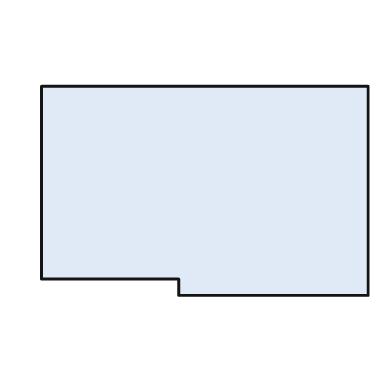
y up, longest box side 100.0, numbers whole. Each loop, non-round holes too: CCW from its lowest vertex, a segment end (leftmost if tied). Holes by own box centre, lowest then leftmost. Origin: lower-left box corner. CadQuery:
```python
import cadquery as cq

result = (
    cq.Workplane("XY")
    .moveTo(42.0, 0.0)
    .lineTo(100.0, 0.0)
    .lineTo(100.0, 64.0)
    .lineTo(0.0, 64.0)
    .lineTo(0.0, 5.0)
    .lineTo(42.0, 5.0)
    .close()
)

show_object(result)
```